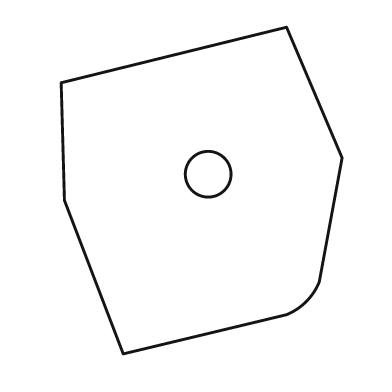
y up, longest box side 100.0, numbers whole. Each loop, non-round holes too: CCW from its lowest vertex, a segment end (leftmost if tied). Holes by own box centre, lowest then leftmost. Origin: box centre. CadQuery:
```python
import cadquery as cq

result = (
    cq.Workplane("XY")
    .moveTo(-24.0, -50.0)
    .lineTo(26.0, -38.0)
    .threePointArc((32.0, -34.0), (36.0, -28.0))
    .lineTo(43.0, 10.0)
    .lineTo(26.0, 50.0)
    .lineTo(-43.0, 33.0)
    .lineTo(-42.0, -3.0)
    .close()
    .moveTo(2.0, 5.0)
    .circle(7.0)
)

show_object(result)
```